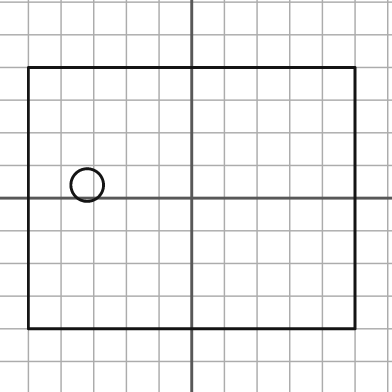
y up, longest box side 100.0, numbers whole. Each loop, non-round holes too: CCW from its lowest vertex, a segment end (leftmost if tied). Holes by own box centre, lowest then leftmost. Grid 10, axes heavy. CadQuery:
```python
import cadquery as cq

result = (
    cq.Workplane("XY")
    .moveTo(-50.0, -40.0)
    .lineTo(50.0, -40.0)
    .lineTo(50.0, 40.0)
    .lineTo(-50.0, 40.0)
    .close()
    .moveTo(-32.0, 4.0)
    .circle(5.0)
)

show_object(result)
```